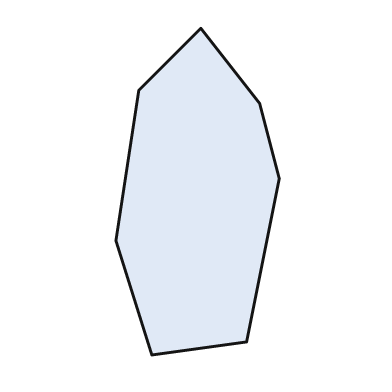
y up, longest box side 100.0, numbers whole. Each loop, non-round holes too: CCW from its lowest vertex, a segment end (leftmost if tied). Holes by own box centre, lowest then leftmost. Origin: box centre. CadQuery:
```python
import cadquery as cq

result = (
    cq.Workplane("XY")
    .moveTo(-14.0, -50.0)
    .lineTo(15.0, -46.0)
    .lineTo(25.0, 4.0)
    .lineTo(19.0, 27.0)
    .lineTo(1.0, 50.0)
    .lineTo(-18.0, 31.0)
    .lineTo(-25.0, -15.0)
    .close()
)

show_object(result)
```